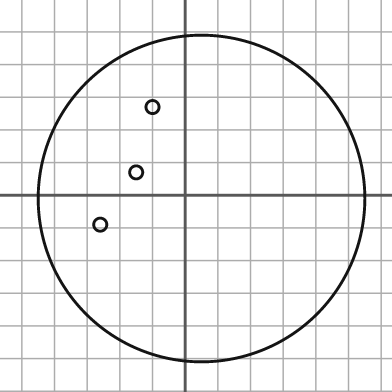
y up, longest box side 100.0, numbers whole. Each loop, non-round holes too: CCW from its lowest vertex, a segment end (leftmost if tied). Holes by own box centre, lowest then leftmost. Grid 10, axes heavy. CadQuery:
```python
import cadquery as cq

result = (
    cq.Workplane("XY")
    .moveTo(5.0, -1.0)
    .circle(50.0)
    .moveTo(-26.0, -9.0)
    .circle(2.0)
    .moveTo(-15.0, 7.0)
    .circle(2.0)
    .moveTo(-10.0, 27.0)
    .circle(2.0)
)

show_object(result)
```